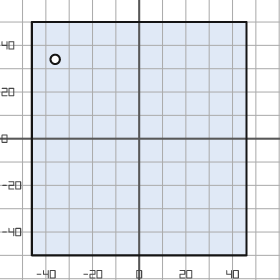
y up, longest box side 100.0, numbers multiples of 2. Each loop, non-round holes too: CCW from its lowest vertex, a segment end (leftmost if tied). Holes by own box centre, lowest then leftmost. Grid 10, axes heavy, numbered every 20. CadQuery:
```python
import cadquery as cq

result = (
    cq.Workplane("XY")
    .moveTo(-46.0, -50.0)
    .lineTo(46.0, -50.0)
    .lineTo(46.0, 50.0)
    .lineTo(-46.0, 50.0)
    .close()
    .moveTo(-36.0, 34.0)
    .circle(2.0)
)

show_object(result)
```